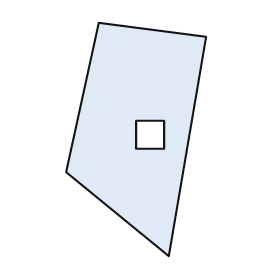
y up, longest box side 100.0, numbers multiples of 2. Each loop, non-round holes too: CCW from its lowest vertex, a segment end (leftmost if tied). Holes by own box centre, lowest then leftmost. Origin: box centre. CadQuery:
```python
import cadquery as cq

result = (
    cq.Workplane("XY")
    .moveTo(14.0, -50.0)
    .lineTo(30.0, 44.0)
    .lineTo(-16.0, 50.0)
    .lineTo(-30.0, -14.0)
    .close()
    .moveTo(0.0, -4.0)
    .lineTo(12.0, -4.0)
    .lineTo(12.0, 8.0)
    .lineTo(0.0, 8.0)
    .close()
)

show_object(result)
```